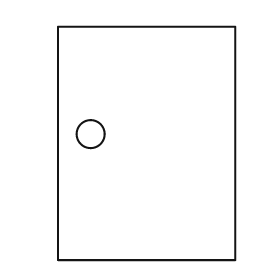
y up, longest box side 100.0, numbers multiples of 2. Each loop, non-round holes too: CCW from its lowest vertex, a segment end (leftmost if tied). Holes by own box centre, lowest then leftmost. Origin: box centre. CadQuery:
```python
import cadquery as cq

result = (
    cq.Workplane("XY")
    .moveTo(-38.0, -50.0)
    .lineTo(38.0, -50.0)
    .lineTo(38.0, 50.0)
    .lineTo(-38.0, 50.0)
    .close()
    .moveTo(-24.0, 4.0)
    .circle(6.0)
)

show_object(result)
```